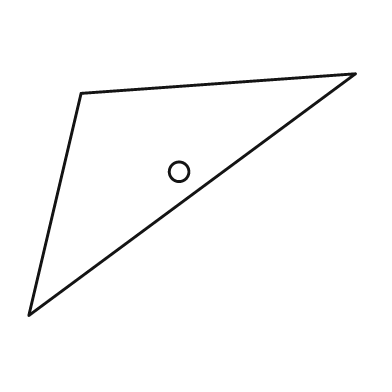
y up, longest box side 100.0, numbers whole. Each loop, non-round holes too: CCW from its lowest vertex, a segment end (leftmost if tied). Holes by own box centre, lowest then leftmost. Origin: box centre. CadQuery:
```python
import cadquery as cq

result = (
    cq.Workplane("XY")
    .moveTo(-50.0, -37.0)
    .lineTo(50.0, 37.0)
    .lineTo(-34.0, 31.0)
    .close()
    .moveTo(-4.0, 7.0)
    .circle(3.0)
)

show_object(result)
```